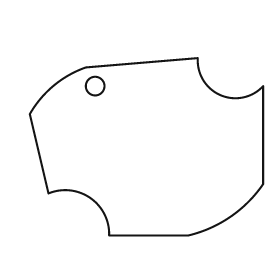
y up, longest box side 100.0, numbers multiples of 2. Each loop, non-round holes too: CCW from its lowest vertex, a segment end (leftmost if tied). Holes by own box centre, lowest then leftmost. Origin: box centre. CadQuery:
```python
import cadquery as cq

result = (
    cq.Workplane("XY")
    .moveTo(-16.0, -38.0)
    .lineTo(18.0, -38.0)
    .threePointArc((36.0, -30.0), (50.0, -16.0))
    .lineTo(50.0, 26.0)
    .threePointArc((32.0, 22.0), (22.0, 38.0))
    .lineTo(-26.0, 34.0)
    .threePointArc((-40.0, 26.0), (-50.0, 14.0))
    .lineTo(-42.0, -20.0)
    .threePointArc((-24.0, -22.0), (-16.0, -38.0))
    .close()
    .moveTo(-22.0, 26.0)
    .circle(4.0)
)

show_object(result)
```